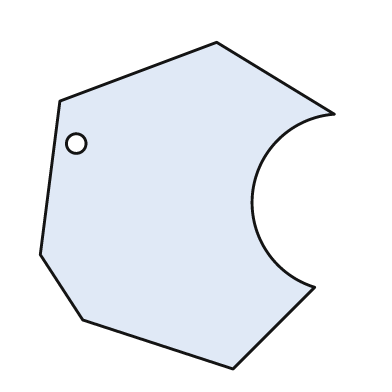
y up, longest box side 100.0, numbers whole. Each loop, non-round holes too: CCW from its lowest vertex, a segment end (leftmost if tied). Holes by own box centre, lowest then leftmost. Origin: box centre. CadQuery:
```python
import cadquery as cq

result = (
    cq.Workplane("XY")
    .moveTo(14.0, -50.0)
    .lineTo(39.0, -25.0)
    .threePointArc((20.0, 4.0), (45.0, 28.0))
    .lineTo(9.0, 50.0)
    .lineTo(-39.0, 32.0)
    .lineTo(-45.0, -15.0)
    .lineTo(-32.0, -35.0)
    .close()
    .moveTo(-34.0, 19.0)
    .circle(3.0)
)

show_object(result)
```